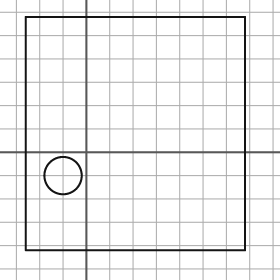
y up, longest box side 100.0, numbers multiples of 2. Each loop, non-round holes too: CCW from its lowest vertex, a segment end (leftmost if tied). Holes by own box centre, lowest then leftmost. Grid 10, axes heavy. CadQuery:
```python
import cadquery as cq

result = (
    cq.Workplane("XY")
    .moveTo(-26.0, -42.0)
    .lineTo(68.0, -42.0)
    .lineTo(68.0, 58.0)
    .lineTo(-26.0, 58.0)
    .close()
    .moveTo(-10.0, -10.0)
    .circle(8.0)
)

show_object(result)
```